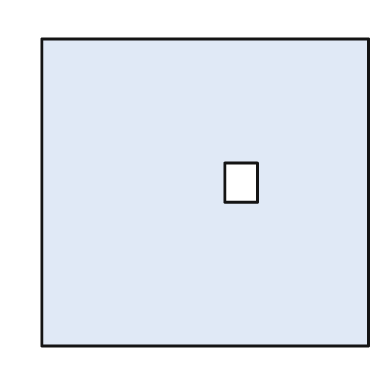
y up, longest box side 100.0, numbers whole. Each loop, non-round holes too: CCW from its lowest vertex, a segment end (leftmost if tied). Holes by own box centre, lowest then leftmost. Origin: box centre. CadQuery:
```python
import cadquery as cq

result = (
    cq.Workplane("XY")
    .moveTo(-50.0, -47.0)
    .lineTo(50.0, -47.0)
    .lineTo(50.0, 47.0)
    .lineTo(-50.0, 47.0)
    .close()
    .moveTo(6.0, -3.0)
    .lineTo(16.0, -3.0)
    .lineTo(16.0, 9.0)
    .lineTo(6.0, 9.0)
    .close()
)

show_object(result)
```